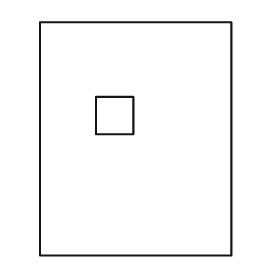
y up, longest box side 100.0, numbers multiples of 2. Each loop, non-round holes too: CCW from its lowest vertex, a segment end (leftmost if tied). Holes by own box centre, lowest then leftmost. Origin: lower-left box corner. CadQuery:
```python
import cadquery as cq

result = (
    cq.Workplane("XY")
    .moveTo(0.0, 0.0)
    .lineTo(82.0, 0.0)
    .lineTo(82.0, 100.0)
    .lineTo(0.0, 100.0)
    .close()
    .moveTo(24.0, 52.0)
    .lineTo(40.0, 52.0)
    .lineTo(40.0, 68.0)
    .lineTo(24.0, 68.0)
    .close()
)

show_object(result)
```